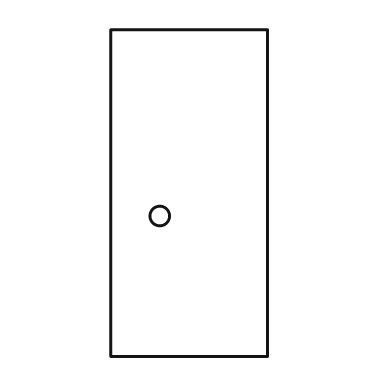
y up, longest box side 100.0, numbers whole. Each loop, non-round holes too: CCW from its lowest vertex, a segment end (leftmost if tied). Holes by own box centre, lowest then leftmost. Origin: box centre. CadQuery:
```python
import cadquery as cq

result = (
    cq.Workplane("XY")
    .moveTo(-24.0, -50.0)
    .lineTo(24.0, -50.0)
    .lineTo(24.0, 50.0)
    .lineTo(-24.0, 50.0)
    .close()
    .moveTo(-9.0, -7.0)
    .circle(3.0)
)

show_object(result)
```